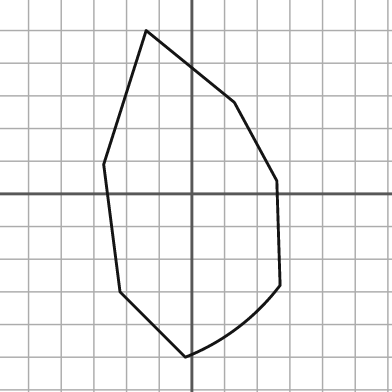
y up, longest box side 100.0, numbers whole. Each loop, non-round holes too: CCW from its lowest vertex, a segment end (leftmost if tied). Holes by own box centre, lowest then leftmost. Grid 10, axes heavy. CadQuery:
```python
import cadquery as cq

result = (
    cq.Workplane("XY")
    .moveTo(-2.0, -50.0)
    .threePointArc((14.0, -41.0), (27.0, -28.0))
    .lineTo(26.0, 4.0)
    .lineTo(13.0, 28.0)
    .lineTo(-14.0, 50.0)
    .lineTo(-27.0, 9.0)
    .lineTo(-22.0, -30.0)
    .close()
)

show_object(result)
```